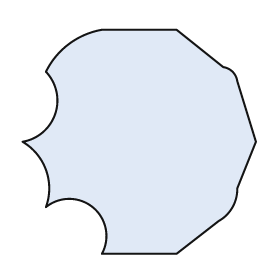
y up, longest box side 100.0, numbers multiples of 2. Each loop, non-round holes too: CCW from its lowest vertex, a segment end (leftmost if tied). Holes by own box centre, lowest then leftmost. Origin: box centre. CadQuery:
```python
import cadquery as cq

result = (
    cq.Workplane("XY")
    .moveTo(-16.0, -48.0)
    .lineTo(16.0, -48.0)
    .lineTo(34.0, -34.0)
    .threePointArc((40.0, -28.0), (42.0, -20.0))
    .lineTo(50.0, 0.0)
    .lineTo(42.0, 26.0)
    .threePointArc((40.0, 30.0), (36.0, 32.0))
    .lineTo(16.0, 48.0)
    .lineTo(-16.0, 48.0)
    .threePointArc((-30.0, 42.0), (-40.0, 30.0))
    .threePointArc((-36.0, 12.0), (-50.0, 0.0))
    .threePointArc((-40.0, -12.0), (-40.0, -28.0))
    .threePointArc((-20.0, -28.0), (-16.0, -48.0))
    .close()
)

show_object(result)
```